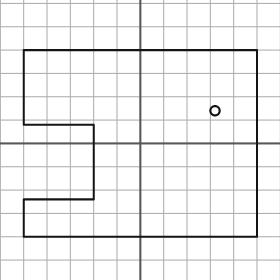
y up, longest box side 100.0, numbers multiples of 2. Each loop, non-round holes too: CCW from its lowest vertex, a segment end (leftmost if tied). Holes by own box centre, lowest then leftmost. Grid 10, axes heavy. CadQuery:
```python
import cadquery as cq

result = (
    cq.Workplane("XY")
    .moveTo(-50.0, -40.0)
    .lineTo(50.0, -40.0)
    .lineTo(50.0, 40.0)
    .lineTo(-50.0, 40.0)
    .lineTo(-50.0, 8.0)
    .lineTo(-20.0, 8.0)
    .lineTo(-20.0, -24.0)
    .lineTo(-50.0, -24.0)
    .close()
    .moveTo(32.0, 14.0)
    .circle(2.0)
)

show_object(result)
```